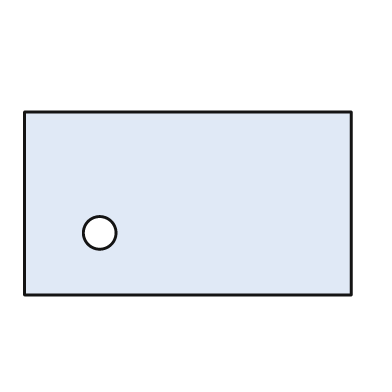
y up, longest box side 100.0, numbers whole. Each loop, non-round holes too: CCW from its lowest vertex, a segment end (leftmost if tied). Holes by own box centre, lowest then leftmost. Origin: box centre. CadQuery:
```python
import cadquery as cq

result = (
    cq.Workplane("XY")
    .moveTo(-50.0, -28.0)
    .lineTo(50.0, -28.0)
    .lineTo(50.0, 28.0)
    .lineTo(-50.0, 28.0)
    .close()
    .moveTo(-27.0, -9.0)
    .circle(5.0)
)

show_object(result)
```